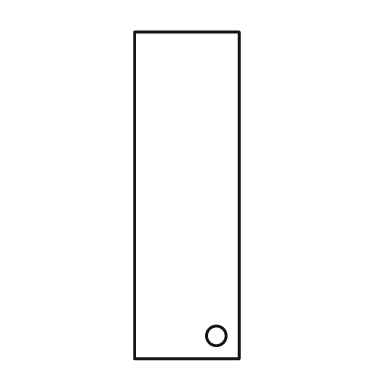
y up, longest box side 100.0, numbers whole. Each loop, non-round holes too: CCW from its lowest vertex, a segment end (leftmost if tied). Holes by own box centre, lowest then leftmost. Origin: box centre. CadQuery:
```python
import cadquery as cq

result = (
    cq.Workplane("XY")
    .moveTo(-16.0, -50.0)
    .lineTo(16.0, -50.0)
    .lineTo(16.0, 50.0)
    .lineTo(-16.0, 50.0)
    .close()
    .moveTo(9.0, -43.0)
    .circle(3.0)
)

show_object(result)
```